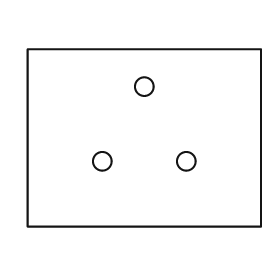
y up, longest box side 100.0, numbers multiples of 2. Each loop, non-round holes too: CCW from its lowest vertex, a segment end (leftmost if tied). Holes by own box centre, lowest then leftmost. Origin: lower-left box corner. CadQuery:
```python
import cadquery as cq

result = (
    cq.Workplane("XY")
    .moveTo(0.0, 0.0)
    .lineTo(100.0, 0.0)
    .lineTo(100.0, 76.0)
    .lineTo(0.0, 76.0)
    .close()
    .moveTo(32.0, 28.0)
    .circle(4.0)
    .moveTo(68.0, 28.0)
    .circle(4.0)
    .moveTo(50.0, 60.0)
    .circle(4.0)
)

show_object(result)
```